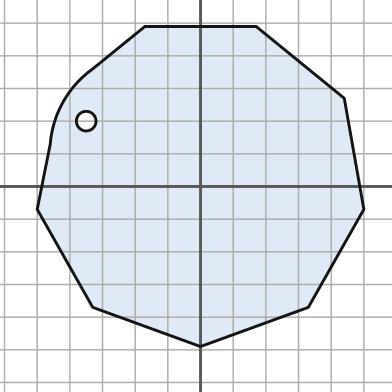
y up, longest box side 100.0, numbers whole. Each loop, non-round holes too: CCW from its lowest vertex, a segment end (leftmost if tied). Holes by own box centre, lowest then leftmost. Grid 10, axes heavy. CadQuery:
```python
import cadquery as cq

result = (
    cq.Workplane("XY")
    .moveTo(0.0, -49.0)
    .lineTo(33.0, -37.0)
    .lineTo(50.0, -7.0)
    .lineTo(44.0, 27.0)
    .lineTo(17.0, 49.0)
    .lineTo(-17.0, 49.0)
    .lineTo(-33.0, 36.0)
    .threePointArc((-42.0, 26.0), (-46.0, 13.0))
    .lineTo(-50.0, -7.0)
    .lineTo(-33.0, -37.0)
    .close()
    .moveTo(-35.0, 20.0)
    .circle(3.0)
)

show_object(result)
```